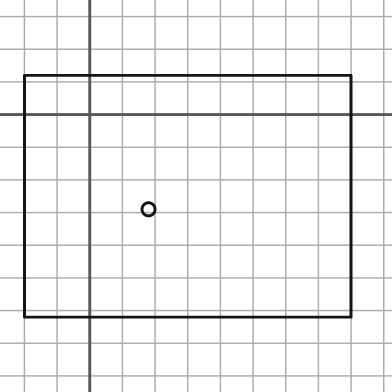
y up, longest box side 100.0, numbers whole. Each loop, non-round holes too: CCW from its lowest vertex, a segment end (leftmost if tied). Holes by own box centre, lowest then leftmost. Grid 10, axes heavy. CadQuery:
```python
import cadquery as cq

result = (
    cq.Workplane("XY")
    .moveTo(-20.0, -62.0)
    .lineTo(80.0, -62.0)
    .lineTo(80.0, 12.0)
    .lineTo(-20.0, 12.0)
    .close()
    .moveTo(18.0, -29.0)
    .circle(2.0)
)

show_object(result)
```